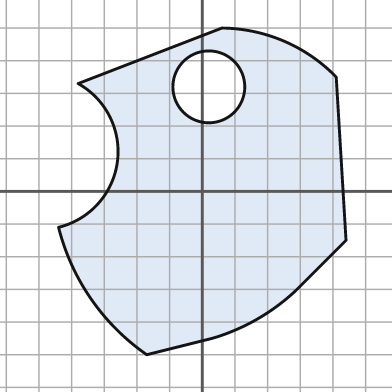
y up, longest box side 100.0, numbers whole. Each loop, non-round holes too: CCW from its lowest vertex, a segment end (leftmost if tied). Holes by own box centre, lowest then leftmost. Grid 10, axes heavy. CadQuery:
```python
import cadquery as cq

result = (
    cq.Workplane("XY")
    .moveTo(-17.0, -50.0)
    .lineTo(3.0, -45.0)
    .threePointArc((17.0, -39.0), (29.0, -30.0))
    .lineTo(44.0, -15.0)
    .lineTo(41.0, 35.0)
    .threePointArc((25.0, 46.0), (6.0, 50.0))
    .lineTo(-38.0, 33.0)
    .threePointArc((-26.0, 9.0), (-44.0, -11.0))
    .threePointArc((-34.0, -33.0), (-17.0, -50.0))
    .close()
    .moveTo(2.0, 32.0)
    .circle(11.0)
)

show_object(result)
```